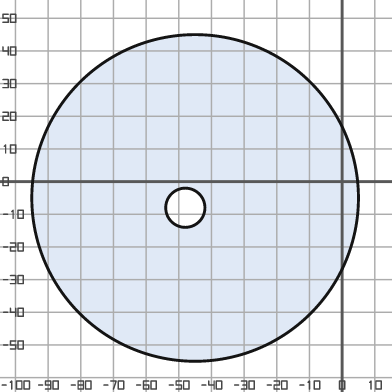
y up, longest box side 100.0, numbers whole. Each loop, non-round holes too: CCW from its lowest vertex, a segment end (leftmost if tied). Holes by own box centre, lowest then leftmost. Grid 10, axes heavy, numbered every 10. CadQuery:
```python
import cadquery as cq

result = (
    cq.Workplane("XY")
    .moveTo(-45.0, -5.0)
    .circle(50.0)
    .moveTo(-48.0, -8.0)
    .circle(6.0)
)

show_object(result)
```